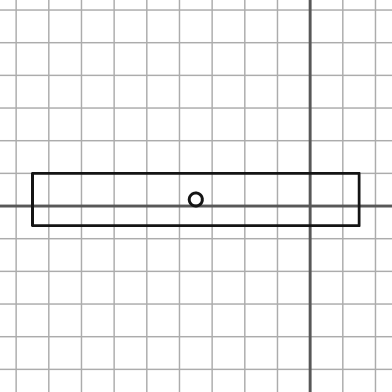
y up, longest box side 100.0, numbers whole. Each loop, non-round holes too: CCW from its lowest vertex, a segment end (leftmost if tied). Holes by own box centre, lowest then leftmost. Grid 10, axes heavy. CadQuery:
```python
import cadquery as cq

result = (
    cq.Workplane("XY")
    .moveTo(-85.0, -6.0)
    .lineTo(15.0, -6.0)
    .lineTo(15.0, 10.0)
    .lineTo(-85.0, 10.0)
    .close()
    .moveTo(-35.0, 2.0)
    .circle(2.0)
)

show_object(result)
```